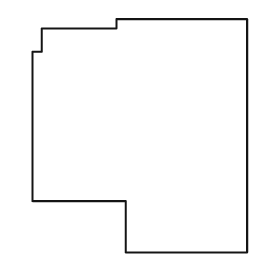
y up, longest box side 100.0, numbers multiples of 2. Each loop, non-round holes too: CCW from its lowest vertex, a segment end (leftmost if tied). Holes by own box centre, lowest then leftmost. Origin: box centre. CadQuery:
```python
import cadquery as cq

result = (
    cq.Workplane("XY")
    .moveTo(-6.0, -50.0)
    .lineTo(46.0, -50.0)
    .lineTo(46.0, 50.0)
    .lineTo(-10.0, 50.0)
    .lineTo(-10.0, 46.0)
    .lineTo(-42.0, 46.0)
    .lineTo(-42.0, 36.0)
    .lineTo(-46.0, 36.0)
    .lineTo(-46.0, -28.0)
    .lineTo(-6.0, -28.0)
    .close()
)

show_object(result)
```